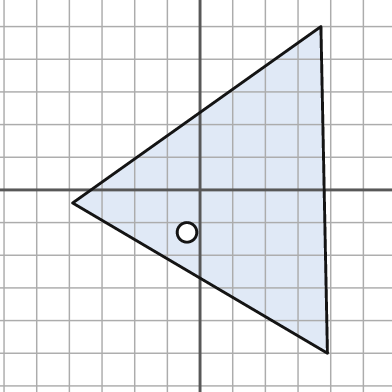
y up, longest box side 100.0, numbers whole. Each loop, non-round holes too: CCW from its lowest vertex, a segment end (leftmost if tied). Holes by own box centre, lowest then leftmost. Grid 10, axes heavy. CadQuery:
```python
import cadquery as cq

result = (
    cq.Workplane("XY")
    .moveTo(39.0, -50.0)
    .lineTo(37.0, 50.0)
    .lineTo(-39.0, -4.0)
    .close()
    .moveTo(-4.0, -13.0)
    .circle(3.0)
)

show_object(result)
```